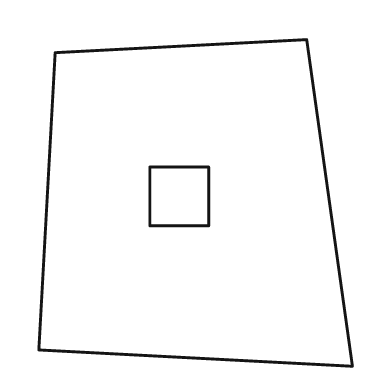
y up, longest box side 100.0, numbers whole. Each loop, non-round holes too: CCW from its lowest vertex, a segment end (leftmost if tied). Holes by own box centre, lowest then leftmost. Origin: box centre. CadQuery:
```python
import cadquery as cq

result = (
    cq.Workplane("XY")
    .moveTo(48.0, -50.0)
    .lineTo(34.0, 50.0)
    .lineTo(-43.0, 46.0)
    .lineTo(-48.0, -45.0)
    .close()
    .moveTo(-14.0, -7.0)
    .lineTo(4.0, -7.0)
    .lineTo(4.0, 11.0)
    .lineTo(-14.0, 11.0)
    .close()
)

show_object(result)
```